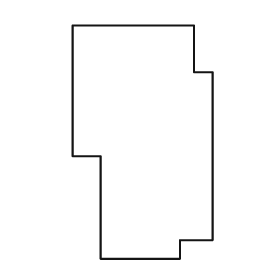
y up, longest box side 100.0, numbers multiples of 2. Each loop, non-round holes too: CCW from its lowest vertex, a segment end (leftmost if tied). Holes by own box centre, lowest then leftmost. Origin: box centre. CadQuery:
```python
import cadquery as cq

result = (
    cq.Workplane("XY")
    .moveTo(-18.0, -50.0)
    .lineTo(16.0, -50.0)
    .lineTo(16.0, -42.0)
    .lineTo(30.0, -42.0)
    .lineTo(30.0, 30.0)
    .lineTo(22.0, 30.0)
    .lineTo(22.0, 50.0)
    .lineTo(-30.0, 50.0)
    .lineTo(-30.0, -6.0)
    .lineTo(-18.0, -6.0)
    .close()
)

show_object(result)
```